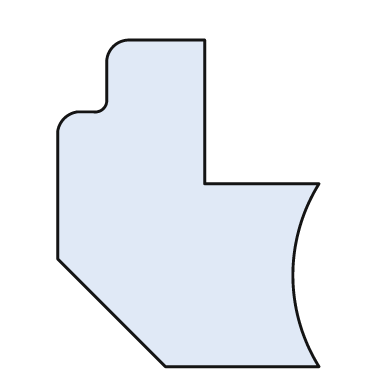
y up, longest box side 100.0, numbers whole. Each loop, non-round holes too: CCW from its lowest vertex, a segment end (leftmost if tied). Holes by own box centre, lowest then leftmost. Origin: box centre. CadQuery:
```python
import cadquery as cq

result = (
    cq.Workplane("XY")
    .moveTo(-7.0, -50.0)
    .lineTo(40.0, -50.0)
    .threePointArc((32.0, -22.0), (40.0, 6.0))
    .lineTo(5.0, 6.0)
    .lineTo(5.0, 50.0)
    .lineTo(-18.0, 50.0)
    .threePointArc((-23.0, 48.0), (-25.0, 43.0))
    .lineTo(-25.0, 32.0)
    .threePointArc((-26.0, 29.0), (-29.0, 28.0))
    .lineTo(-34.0, 28.0)
    .threePointArc((-38.0, 26.0), (-40.0, 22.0))
    .lineTo(-40.0, -17.0)
    .close()
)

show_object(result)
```